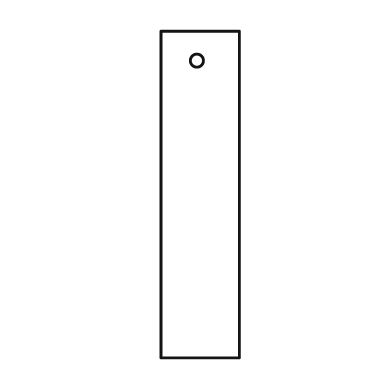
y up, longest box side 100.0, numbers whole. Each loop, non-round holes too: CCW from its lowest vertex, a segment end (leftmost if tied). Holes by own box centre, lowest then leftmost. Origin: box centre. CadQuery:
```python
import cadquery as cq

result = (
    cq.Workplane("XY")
    .moveTo(-12.0, -50.0)
    .lineTo(12.0, -50.0)
    .lineTo(12.0, 50.0)
    .lineTo(-12.0, 50.0)
    .close()
    .moveTo(-1.0, 41.0)
    .circle(2.0)
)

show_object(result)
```